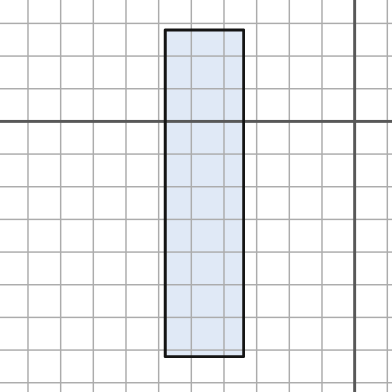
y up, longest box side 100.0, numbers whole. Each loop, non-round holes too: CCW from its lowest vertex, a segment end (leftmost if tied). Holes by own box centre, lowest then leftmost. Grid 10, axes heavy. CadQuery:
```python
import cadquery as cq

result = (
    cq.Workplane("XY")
    .moveTo(-58.0, -72.0)
    .lineTo(-34.0, -72.0)
    .lineTo(-34.0, 28.0)
    .lineTo(-58.0, 28.0)
    .close()
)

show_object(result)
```